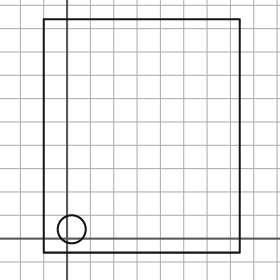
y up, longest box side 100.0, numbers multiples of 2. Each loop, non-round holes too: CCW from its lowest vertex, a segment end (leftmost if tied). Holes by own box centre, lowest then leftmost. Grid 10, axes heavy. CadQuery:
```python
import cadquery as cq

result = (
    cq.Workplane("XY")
    .moveTo(-10.0, -6.0)
    .lineTo(74.0, -6.0)
    .lineTo(74.0, 94.0)
    .lineTo(-10.0, 94.0)
    .close()
    .moveTo(2.0, 4.0)
    .circle(6.0)
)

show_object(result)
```